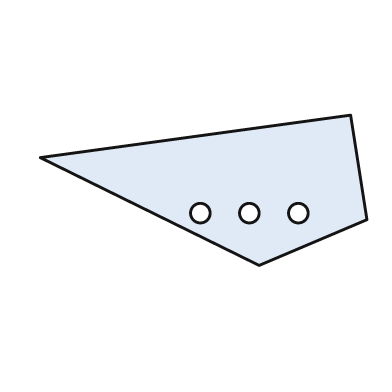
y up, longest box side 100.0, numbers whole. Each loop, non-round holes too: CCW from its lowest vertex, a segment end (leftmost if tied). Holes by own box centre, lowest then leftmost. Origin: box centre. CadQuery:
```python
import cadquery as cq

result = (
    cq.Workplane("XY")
    .moveTo(17.0, -23.0)
    .lineTo(50.0, -9.0)
    .lineTo(45.0, 23.0)
    .lineTo(-50.0, 10.0)
    .close()
    .moveTo(-1.0, -7.0)
    .circle(3.0)
    .moveTo(14.0, -7.0)
    .circle(3.0)
    .moveTo(29.0, -7.0)
    .circle(3.0)
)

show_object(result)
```